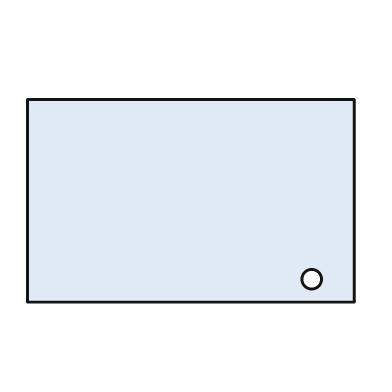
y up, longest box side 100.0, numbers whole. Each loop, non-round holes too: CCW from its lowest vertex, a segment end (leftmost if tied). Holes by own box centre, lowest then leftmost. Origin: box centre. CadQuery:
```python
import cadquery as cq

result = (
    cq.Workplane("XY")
    .moveTo(-50.0, -31.0)
    .lineTo(50.0, -31.0)
    .lineTo(50.0, 31.0)
    .lineTo(-50.0, 31.0)
    .close()
    .moveTo(37.0, -24.0)
    .circle(3.0)
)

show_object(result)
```